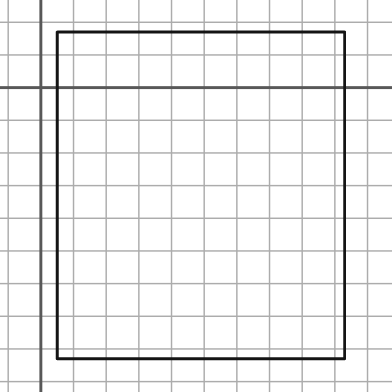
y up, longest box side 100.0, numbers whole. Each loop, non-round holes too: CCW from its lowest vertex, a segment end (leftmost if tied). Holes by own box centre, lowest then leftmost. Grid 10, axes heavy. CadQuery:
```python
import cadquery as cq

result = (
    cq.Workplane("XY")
    .moveTo(5.0, -83.0)
    .lineTo(93.0, -83.0)
    .lineTo(93.0, 17.0)
    .lineTo(5.0, 17.0)
    .close()
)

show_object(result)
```